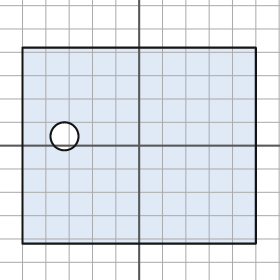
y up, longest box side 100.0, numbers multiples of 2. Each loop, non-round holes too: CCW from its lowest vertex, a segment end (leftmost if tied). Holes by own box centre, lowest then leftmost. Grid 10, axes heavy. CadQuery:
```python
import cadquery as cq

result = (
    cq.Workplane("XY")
    .moveTo(-50.0, -42.0)
    .lineTo(50.0, -42.0)
    .lineTo(50.0, 42.0)
    .lineTo(-50.0, 42.0)
    .close()
    .moveTo(-32.0, 4.0)
    .circle(6.0)
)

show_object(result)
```